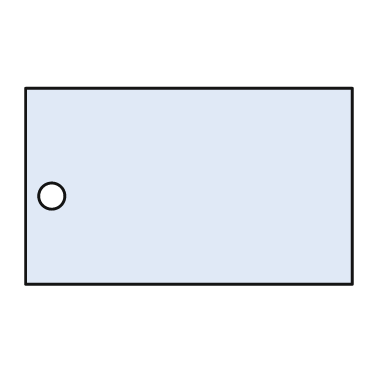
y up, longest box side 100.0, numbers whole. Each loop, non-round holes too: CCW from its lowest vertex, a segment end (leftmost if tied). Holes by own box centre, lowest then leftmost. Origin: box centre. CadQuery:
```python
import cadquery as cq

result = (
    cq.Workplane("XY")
    .moveTo(-50.0, -30.0)
    .lineTo(50.0, -30.0)
    .lineTo(50.0, 30.0)
    .lineTo(-50.0, 30.0)
    .close()
    .moveTo(-42.0, -3.0)
    .circle(4.0)
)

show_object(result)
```